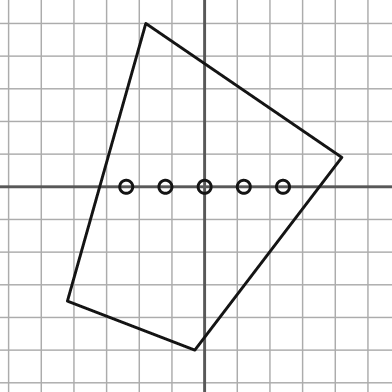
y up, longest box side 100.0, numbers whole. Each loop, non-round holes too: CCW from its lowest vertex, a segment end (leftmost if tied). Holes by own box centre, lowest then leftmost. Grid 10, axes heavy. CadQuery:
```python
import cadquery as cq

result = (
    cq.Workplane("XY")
    .moveTo(-3.0, -50.0)
    .lineTo(42.0, 9.0)
    .lineTo(-18.0, 50.0)
    .lineTo(-42.0, -35.0)
    .close()
    .moveTo(-24.0, 0.0)
    .circle(2.0)
    .moveTo(-12.0, 0.0)
    .circle(2.0)
    .moveTo(0.0, 0.0)
    .circle(2.0)
    .moveTo(12.0, 0.0)
    .circle(2.0)
    .moveTo(24.0, 0.0)
    .circle(2.0)
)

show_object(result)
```